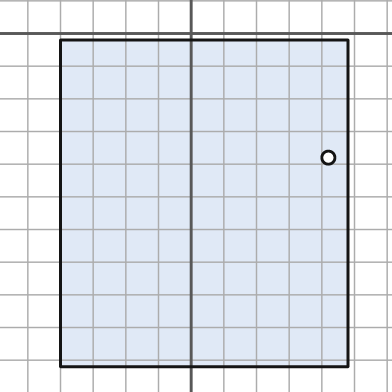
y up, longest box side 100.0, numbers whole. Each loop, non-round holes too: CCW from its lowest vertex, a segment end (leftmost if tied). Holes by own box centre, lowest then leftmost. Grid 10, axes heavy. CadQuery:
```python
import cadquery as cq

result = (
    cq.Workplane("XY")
    .moveTo(-40.0, -102.0)
    .lineTo(48.0, -102.0)
    .lineTo(48.0, -2.0)
    .lineTo(-40.0, -2.0)
    .close()
    .moveTo(42.0, -38.0)
    .circle(2.0)
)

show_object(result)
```